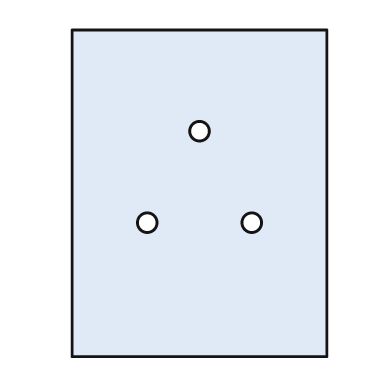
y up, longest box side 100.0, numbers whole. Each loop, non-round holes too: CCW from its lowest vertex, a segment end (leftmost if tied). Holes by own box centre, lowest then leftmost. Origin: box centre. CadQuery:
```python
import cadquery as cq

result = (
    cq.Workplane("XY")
    .moveTo(-39.0, -50.0)
    .lineTo(39.0, -50.0)
    .lineTo(39.0, 50.0)
    .lineTo(-39.0, 50.0)
    .close()
    .moveTo(-16.0, -9.0)
    .circle(3.0)
    .moveTo(16.0, -9.0)
    .circle(3.0)
    .moveTo(0.0, 19.0)
    .circle(3.0)
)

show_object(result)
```